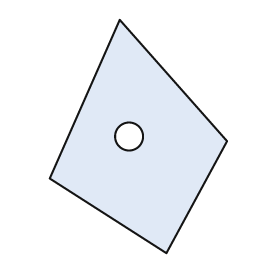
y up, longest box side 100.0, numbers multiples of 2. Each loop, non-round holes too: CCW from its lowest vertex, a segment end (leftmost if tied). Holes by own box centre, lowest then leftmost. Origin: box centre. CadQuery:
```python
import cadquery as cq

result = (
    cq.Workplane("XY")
    .moveTo(12.0, -50.0)
    .lineTo(38.0, -2.0)
    .lineTo(-8.0, 50.0)
    .lineTo(-38.0, -18.0)
    .close()
    .moveTo(-4.0, 0.0)
    .circle(6.0)
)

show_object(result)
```